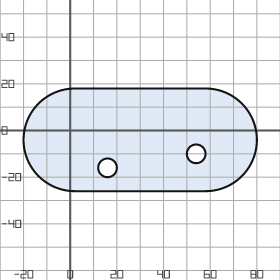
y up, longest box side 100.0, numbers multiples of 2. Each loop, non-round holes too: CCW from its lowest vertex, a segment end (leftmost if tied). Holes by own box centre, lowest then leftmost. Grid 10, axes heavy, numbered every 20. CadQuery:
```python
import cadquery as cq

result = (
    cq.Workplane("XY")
    .moveTo(2.0, -26.0)
    .lineTo(58.0, -26.0)
    .threePointArc((80.0, -4.0), (58.0, 18.0))
    .lineTo(2.0, 18.0)
    .threePointArc((-20.0, -4.0), (2.0, -26.0))
    .close()
    .moveTo(16.0, -16.0)
    .circle(4.0)
    .moveTo(54.0, -10.0)
    .circle(4.0)
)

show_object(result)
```